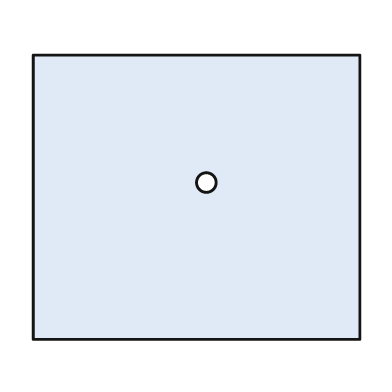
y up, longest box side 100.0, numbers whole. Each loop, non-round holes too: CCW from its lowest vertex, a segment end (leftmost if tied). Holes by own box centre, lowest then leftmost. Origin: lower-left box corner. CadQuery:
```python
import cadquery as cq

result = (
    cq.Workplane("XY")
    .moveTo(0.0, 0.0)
    .lineTo(100.0, 0.0)
    .lineTo(100.0, 87.0)
    .lineTo(0.0, 87.0)
    .close()
    .moveTo(53.0, 48.0)
    .circle(3.0)
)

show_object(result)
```